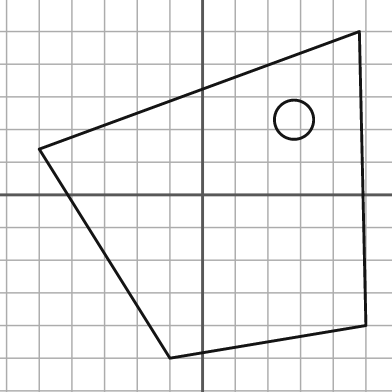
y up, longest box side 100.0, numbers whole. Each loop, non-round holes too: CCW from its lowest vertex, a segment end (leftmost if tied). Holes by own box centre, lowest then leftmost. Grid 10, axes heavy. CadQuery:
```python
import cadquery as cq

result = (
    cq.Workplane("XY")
    .moveTo(-10.0, -50.0)
    .lineTo(50.0, -40.0)
    .lineTo(48.0, 50.0)
    .lineTo(-50.0, 14.0)
    .close()
    .moveTo(28.0, 23.0)
    .circle(6.0)
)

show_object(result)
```